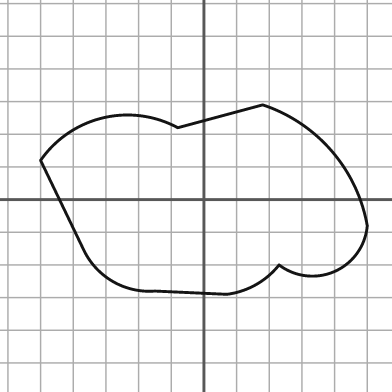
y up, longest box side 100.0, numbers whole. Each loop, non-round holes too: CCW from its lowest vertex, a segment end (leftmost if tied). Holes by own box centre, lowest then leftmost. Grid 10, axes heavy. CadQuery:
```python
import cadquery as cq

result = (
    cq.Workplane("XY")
    .moveTo(7.0, -29.0)
    .threePointArc((16.0, -26.0), (23.0, -20.0))
    .threePointArc((40.0, -22.0), (50.0, -8.0))
    .threePointArc((39.0, 15.0), (18.0, 29.0))
    .lineTo(-8.0, 22.0)
    .threePointArc((-31.0, 25.0), (-50.0, 12.0))
    .lineTo(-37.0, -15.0)
    .threePointArc((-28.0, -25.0), (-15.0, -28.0))
    .close()
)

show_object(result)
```